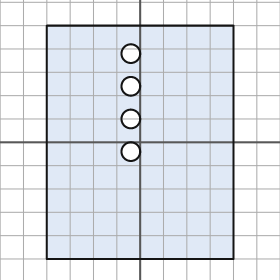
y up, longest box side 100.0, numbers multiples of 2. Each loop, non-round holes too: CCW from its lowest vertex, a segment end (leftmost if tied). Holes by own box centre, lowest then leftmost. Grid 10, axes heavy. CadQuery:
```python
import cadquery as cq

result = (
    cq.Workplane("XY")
    .moveTo(-40.0, -50.0)
    .lineTo(40.0, -50.0)
    .lineTo(40.0, 50.0)
    .lineTo(-40.0, 50.0)
    .close()
    .moveTo(-4.0, -4.0)
    .circle(4.0)
    .moveTo(-4.0, 10.0)
    .circle(4.0)
    .moveTo(-4.0, 24.0)
    .circle(4.0)
    .moveTo(-4.0, 38.0)
    .circle(4.0)
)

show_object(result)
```